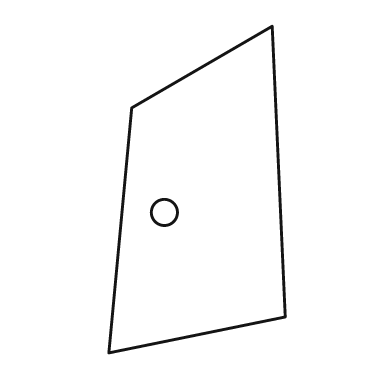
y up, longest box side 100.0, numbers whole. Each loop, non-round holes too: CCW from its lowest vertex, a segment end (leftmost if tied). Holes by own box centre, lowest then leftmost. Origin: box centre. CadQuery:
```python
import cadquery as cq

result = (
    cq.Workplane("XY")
    .moveTo(-27.0, -50.0)
    .lineTo(27.0, -39.0)
    .lineTo(23.0, 50.0)
    .lineTo(-20.0, 25.0)
    .close()
    .moveTo(-10.0, -7.0)
    .circle(4.0)
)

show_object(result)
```